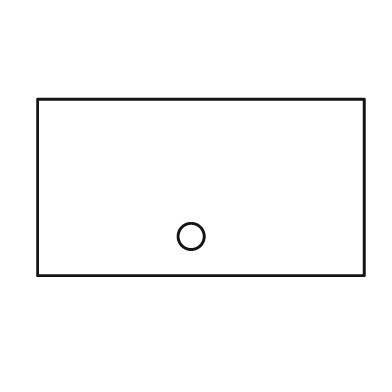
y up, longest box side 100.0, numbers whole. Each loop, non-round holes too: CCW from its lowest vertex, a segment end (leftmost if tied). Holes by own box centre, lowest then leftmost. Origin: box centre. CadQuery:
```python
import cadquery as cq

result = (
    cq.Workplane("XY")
    .moveTo(-50.0, -27.0)
    .lineTo(50.0, -27.0)
    .lineTo(50.0, 27.0)
    .lineTo(-50.0, 27.0)
    .close()
    .moveTo(-3.0, -15.0)
    .circle(4.0)
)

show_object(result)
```